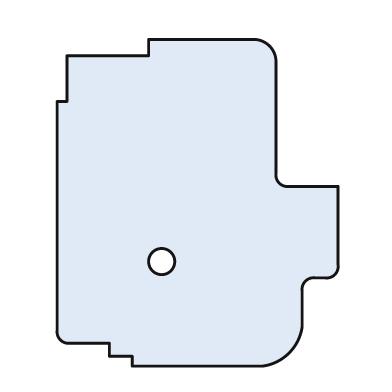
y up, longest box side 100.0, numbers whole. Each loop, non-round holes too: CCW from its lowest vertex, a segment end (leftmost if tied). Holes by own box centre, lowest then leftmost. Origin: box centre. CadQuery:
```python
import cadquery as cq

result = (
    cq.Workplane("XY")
    .moveTo(-20.0, -50.0)
    .lineTo(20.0, -50.0)
    .threePointArc((28.0, -46.0), (32.0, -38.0))
    .lineTo(32.0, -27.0)
    .threePointArc((33.0, -24.0), (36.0, -23.0))
    .lineTo(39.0, -23.0)
    .threePointArc((42.0, -22.0), (43.0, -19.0))
    .lineTo(43.0, 5.0)
    .lineTo(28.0, 5.0)
    .threePointArc((25.0, 6.0), (24.0, 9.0))
    .lineTo(24.0, 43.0)
    .threePointArc((22.0, 48.0), (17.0, 50.0))
    .lineTo(-15.0, 50.0)
    .lineTo(-15.0, 45.0)
    .lineTo(-40.0, 45.0)
    .lineTo(-40.0, 31.0)
    .lineTo(-43.0, 31.0)
    .lineTo(-43.0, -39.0)
    .threePointArc((-42.0, -42.0), (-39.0, -43.0))
    .lineTo(-27.0, -43.0)
    .lineTo(-27.0, -47.0)
    .lineTo(-20.0, -47.0)
    .close()
    .moveTo(-11.0, -18.0)
    .circle(4.0)
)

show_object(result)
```